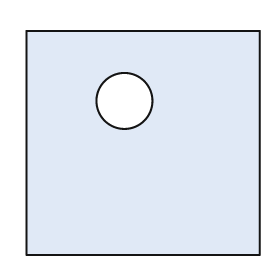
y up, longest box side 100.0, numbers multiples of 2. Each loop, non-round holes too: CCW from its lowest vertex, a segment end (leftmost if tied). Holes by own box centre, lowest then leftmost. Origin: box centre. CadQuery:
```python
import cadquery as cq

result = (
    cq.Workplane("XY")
    .moveTo(-50.0, -48.0)
    .lineTo(50.0, -48.0)
    .lineTo(50.0, 48.0)
    .lineTo(-50.0, 48.0)
    .close()
    .moveTo(-8.0, 18.0)
    .circle(12.0)
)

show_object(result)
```